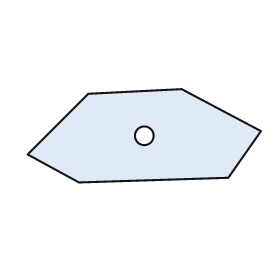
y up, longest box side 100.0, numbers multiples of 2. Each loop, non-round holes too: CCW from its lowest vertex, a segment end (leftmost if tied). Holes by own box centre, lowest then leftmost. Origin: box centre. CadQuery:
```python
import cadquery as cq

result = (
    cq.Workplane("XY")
    .moveTo(-28.0, -20.0)
    .lineTo(36.0, -18.0)
    .lineTo(50.0, 2.0)
    .lineTo(16.0, 20.0)
    .lineTo(-24.0, 18.0)
    .lineTo(-50.0, -8.0)
    .close()
    .moveTo(0.0, 0.0)
    .circle(4.0)
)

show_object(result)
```